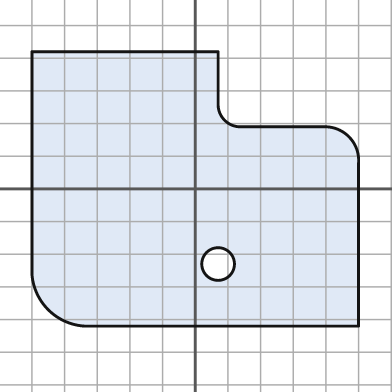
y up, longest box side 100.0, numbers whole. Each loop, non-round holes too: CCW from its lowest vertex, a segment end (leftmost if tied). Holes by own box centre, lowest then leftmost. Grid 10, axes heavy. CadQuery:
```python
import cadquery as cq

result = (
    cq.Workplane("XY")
    .moveTo(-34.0, -42.0)
    .lineTo(50.0, -42.0)
    .lineTo(50.0, 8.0)
    .threePointArc((47.0, 16.0), (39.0, 19.0))
    .lineTo(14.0, 19.0)
    .threePointArc((9.0, 21.0), (7.0, 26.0))
    .lineTo(7.0, 42.0)
    .lineTo(-50.0, 42.0)
    .lineTo(-50.0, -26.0)
    .threePointArc((-45.0, -37.0), (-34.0, -42.0))
    .close()
    .moveTo(7.0, -23.0)
    .circle(5.0)
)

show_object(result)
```